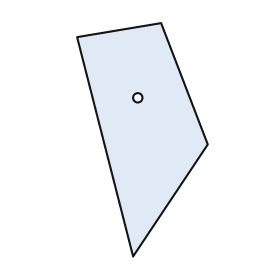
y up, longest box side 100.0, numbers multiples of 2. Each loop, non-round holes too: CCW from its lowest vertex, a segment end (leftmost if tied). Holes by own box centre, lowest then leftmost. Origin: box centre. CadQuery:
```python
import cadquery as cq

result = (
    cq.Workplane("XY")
    .moveTo(-4.0, -50.0)
    .lineTo(28.0, -2.0)
    .lineTo(8.0, 50.0)
    .lineTo(-28.0, 44.0)
    .close()
    .moveTo(-2.0, 18.0)
    .circle(2.0)
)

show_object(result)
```